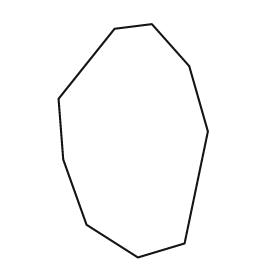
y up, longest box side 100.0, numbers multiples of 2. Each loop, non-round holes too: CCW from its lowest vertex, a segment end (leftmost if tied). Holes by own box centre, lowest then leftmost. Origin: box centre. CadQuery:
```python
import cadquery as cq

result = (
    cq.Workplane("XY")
    .moveTo(2.0, -50.0)
    .lineTo(22.0, -44.0)
    .lineTo(32.0, 4.0)
    .lineTo(24.0, 32.0)
    .lineTo(8.0, 50.0)
    .lineTo(-8.0, 48.0)
    .lineTo(-32.0, 18.0)
    .lineTo(-30.0, -8.0)
    .lineTo(-20.0, -36.0)
    .close()
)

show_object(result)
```